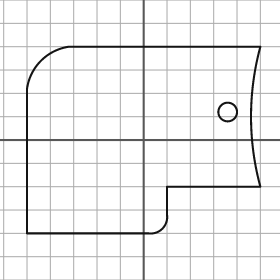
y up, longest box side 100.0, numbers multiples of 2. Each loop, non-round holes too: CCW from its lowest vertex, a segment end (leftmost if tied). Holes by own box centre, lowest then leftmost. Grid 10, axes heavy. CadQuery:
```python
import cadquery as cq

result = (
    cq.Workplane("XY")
    .moveTo(-50.0, -40.0)
    .lineTo(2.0, -40.0)
    .threePointArc((8.0, -38.0), (10.0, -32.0))
    .lineTo(10.0, -20.0)
    .lineTo(50.0, -20.0)
    .threePointArc((46.0, 10.0), (50.0, 40.0))
    .lineTo(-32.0, 40.0)
    .threePointArc((-44.0, 34.0), (-50.0, 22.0))
    .close()
    .moveTo(36.0, 12.0)
    .circle(4.0)
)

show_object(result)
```